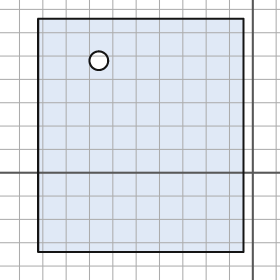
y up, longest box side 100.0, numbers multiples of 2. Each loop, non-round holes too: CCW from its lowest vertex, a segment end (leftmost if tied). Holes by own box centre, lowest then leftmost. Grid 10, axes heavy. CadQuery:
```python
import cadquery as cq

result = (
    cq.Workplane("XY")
    .moveTo(-92.0, -34.0)
    .lineTo(-4.0, -34.0)
    .lineTo(-4.0, 66.0)
    .lineTo(-92.0, 66.0)
    .close()
    .moveTo(-66.0, 48.0)
    .circle(4.0)
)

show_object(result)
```